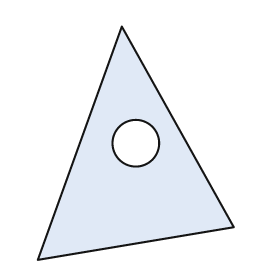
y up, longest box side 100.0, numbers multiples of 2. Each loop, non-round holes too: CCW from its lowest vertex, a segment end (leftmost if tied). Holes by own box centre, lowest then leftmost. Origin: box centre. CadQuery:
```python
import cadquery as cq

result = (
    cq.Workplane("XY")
    .moveTo(-42.0, -50.0)
    .lineTo(42.0, -36.0)
    .lineTo(-6.0, 50.0)
    .close()
    .moveTo(0.0, 0.0)
    .circle(10.0)
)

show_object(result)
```